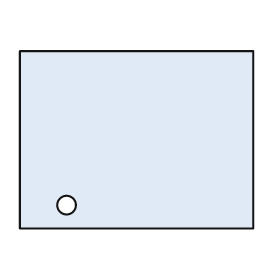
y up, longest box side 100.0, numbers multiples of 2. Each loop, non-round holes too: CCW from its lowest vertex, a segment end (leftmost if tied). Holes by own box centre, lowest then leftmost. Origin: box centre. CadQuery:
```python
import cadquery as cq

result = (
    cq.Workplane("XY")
    .moveTo(-50.0, -38.0)
    .lineTo(50.0, -38.0)
    .lineTo(50.0, 38.0)
    .lineTo(-50.0, 38.0)
    .close()
    .moveTo(-30.0, -28.0)
    .circle(4.0)
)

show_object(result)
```